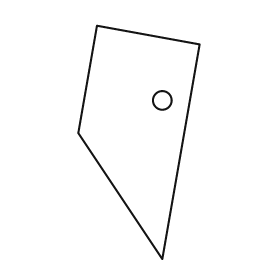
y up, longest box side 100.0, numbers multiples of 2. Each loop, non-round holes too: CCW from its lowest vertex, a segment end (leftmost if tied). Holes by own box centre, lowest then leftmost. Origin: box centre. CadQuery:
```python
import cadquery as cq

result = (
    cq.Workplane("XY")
    .moveTo(10.0, -50.0)
    .lineTo(26.0, 42.0)
    .lineTo(-18.0, 50.0)
    .lineTo(-26.0, 4.0)
    .close()
    .moveTo(10.0, 18.0)
    .circle(4.0)
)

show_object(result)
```